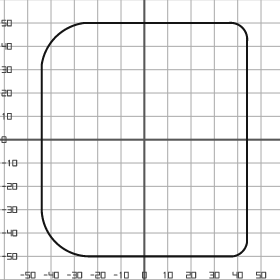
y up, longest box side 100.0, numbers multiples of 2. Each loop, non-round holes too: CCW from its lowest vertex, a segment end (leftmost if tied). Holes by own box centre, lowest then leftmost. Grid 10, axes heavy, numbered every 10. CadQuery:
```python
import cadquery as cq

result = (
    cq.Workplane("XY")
    .moveTo(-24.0, -50.0)
    .lineTo(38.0, -50.0)
    .threePointArc((42.0, -48.0), (44.0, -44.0))
    .lineTo(44.0, 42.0)
    .threePointArc((42.0, 48.0), (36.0, 50.0))
    .lineTo(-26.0, 50.0)
    .threePointArc((-38.0, 44.0), (-44.0, 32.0))
    .lineTo(-44.0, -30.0)
    .threePointArc((-38.0, -44.0), (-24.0, -50.0))
    .close()
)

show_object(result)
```